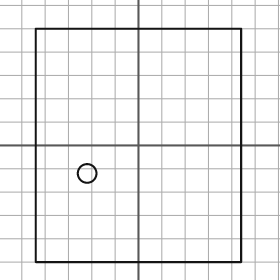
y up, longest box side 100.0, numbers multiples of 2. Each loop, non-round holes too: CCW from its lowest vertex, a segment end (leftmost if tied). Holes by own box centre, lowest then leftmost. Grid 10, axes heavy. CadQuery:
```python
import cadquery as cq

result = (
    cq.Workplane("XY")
    .moveTo(-44.0, -50.0)
    .lineTo(44.0, -50.0)
    .lineTo(44.0, 50.0)
    .lineTo(-44.0, 50.0)
    .close()
    .moveTo(-22.0, -12.0)
    .circle(4.0)
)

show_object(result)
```